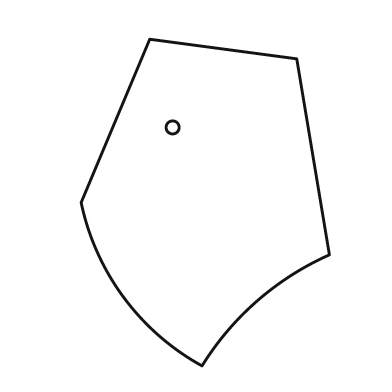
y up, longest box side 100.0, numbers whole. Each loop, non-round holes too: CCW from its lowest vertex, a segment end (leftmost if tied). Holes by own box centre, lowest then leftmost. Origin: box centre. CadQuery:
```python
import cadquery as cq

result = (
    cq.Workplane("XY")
    .moveTo(-1.0, -50.0)
    .threePointArc((16.0, -30.0), (38.0, -16.0))
    .lineTo(28.0, 44.0)
    .lineTo(-17.0, 50.0)
    .lineTo(-38.0, 0.0)
    .threePointArc((-25.0, -29.0), (-1.0, -50.0))
    .close()
    .moveTo(-10.0, 23.0)
    .circle(2.0)
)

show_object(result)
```